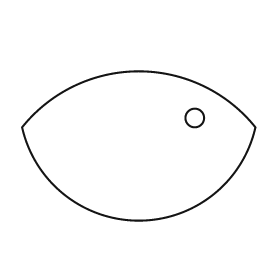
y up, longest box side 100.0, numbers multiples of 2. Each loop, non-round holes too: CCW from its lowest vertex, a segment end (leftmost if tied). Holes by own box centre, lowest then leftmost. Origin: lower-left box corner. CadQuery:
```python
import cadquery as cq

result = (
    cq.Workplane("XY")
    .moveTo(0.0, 40.0)
    .threePointArc((50.0, 0.0), (100.0, 40.0))
    .threePointArc((50.0, 64.0), (0.0, 40.0))
    .close()
    .moveTo(74.0, 44.0)
    .circle(4.0)
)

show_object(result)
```